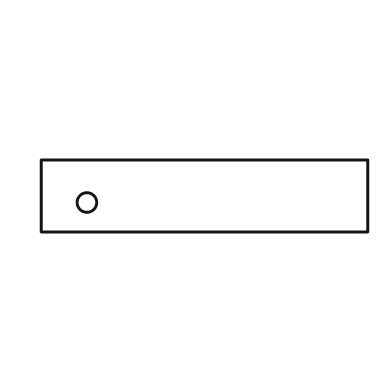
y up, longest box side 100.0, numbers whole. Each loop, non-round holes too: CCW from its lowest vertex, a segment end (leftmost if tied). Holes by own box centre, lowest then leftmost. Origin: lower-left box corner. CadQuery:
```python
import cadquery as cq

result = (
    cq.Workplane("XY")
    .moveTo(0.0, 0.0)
    .lineTo(100.0, 0.0)
    .lineTo(100.0, 22.0)
    .lineTo(0.0, 22.0)
    .close()
    .moveTo(14.0, 9.0)
    .circle(3.0)
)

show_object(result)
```